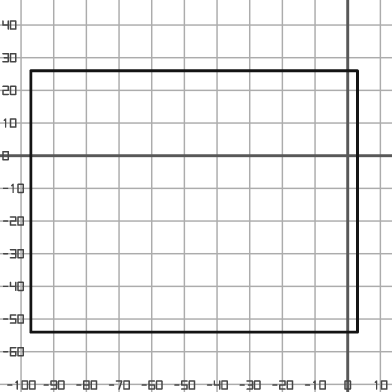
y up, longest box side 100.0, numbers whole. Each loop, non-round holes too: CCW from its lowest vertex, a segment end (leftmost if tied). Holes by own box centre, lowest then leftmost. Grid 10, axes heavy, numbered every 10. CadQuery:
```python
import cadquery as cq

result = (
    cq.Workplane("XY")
    .moveTo(-97.0, -54.0)
    .lineTo(3.0, -54.0)
    .lineTo(3.0, 26.0)
    .lineTo(-97.0, 26.0)
    .close()
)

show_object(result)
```